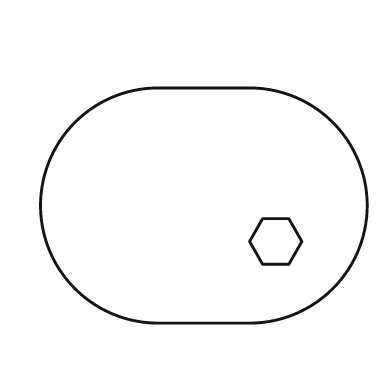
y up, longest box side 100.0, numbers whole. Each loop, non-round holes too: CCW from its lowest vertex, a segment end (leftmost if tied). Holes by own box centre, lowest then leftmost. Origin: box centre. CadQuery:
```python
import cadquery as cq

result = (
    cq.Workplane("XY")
    .moveTo(-14.0, -36.0)
    .lineTo(14.0, -36.0)
    .threePointArc((50.0, 0.0), (14.0, 36.0))
    .lineTo(-14.0, 36.0)
    .threePointArc((-50.0, 0.0), (-14.0, -36.0))
    .close()
    .moveTo(18.0, -18.0)
    .lineTo(26.0, -18.0)
    .lineTo(30.0, -11.0)
    .lineTo(26.0, -4.0)
    .lineTo(18.0, -4.0)
    .lineTo(14.0, -11.0)
    .close()
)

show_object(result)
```